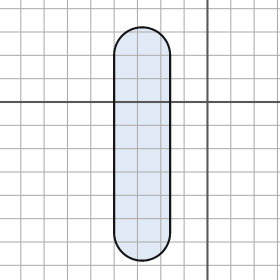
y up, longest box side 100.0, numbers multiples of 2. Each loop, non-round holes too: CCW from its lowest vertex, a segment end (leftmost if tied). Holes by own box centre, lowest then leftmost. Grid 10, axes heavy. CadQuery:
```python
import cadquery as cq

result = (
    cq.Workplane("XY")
    .moveTo(-40.0, -56.0)
    .threePointArc((-28.0, -68.0), (-16.0, -56.0))
    .lineTo(-16.0, 20.0)
    .threePointArc((-28.0, 32.0), (-40.0, 20.0))
    .close()
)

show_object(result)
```